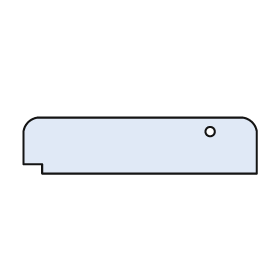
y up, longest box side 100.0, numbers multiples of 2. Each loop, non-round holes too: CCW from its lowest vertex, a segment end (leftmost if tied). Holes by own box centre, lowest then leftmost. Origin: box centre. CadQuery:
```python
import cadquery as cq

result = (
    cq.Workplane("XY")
    .moveTo(-42.0, -12.0)
    .lineTo(50.0, -12.0)
    .lineTo(50.0, 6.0)
    .threePointArc((48.0, 10.0), (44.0, 12.0))
    .lineTo(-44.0, 12.0)
    .threePointArc((-48.0, 10.0), (-50.0, 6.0))
    .lineTo(-50.0, -8.0)
    .lineTo(-42.0, -8.0)
    .close()
    .moveTo(30.0, 6.0)
    .circle(2.0)
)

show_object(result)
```